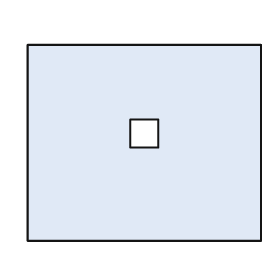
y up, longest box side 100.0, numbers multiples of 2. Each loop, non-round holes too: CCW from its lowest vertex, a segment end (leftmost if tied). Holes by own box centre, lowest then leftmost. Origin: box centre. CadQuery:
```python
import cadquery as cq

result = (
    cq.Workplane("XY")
    .moveTo(-50.0, -42.0)
    .lineTo(50.0, -42.0)
    .lineTo(50.0, 42.0)
    .lineTo(-50.0, 42.0)
    .close()
    .moveTo(-6.0, -2.0)
    .lineTo(6.0, -2.0)
    .lineTo(6.0, 10.0)
    .lineTo(-6.0, 10.0)
    .close()
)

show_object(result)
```